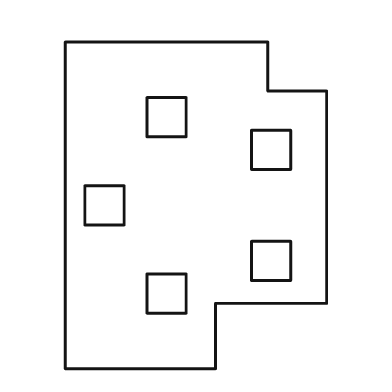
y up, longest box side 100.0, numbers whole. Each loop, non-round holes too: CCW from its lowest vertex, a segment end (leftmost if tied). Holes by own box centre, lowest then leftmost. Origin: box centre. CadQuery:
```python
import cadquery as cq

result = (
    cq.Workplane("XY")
    .moveTo(-40.0, -50.0)
    .lineTo(6.0, -50.0)
    .lineTo(6.0, -30.0)
    .lineTo(40.0, -30.0)
    .lineTo(40.0, 35.0)
    .lineTo(22.0, 35.0)
    .lineTo(22.0, 50.0)
    .lineTo(-40.0, 50.0)
    .close()
    .moveTo(-15.0, -33.0)
    .lineTo(-3.0, -33.0)
    .lineTo(-3.0, -21.0)
    .lineTo(-15.0, -21.0)
    .close()
    .moveTo(17.0, -23.0)
    .lineTo(29.0, -23.0)
    .lineTo(29.0, -11.0)
    .lineTo(17.0, -11.0)
    .close()
    .moveTo(-34.0, -6.0)
    .lineTo(-22.0, -6.0)
    .lineTo(-22.0, 6.0)
    .lineTo(-34.0, 6.0)
    .close()
    .moveTo(17.0, 11.0)
    .lineTo(29.0, 11.0)
    .lineTo(29.0, 23.0)
    .lineTo(17.0, 23.0)
    .close()
    .moveTo(-15.0, 21.0)
    .lineTo(-3.0, 21.0)
    .lineTo(-3.0, 33.0)
    .lineTo(-15.0, 33.0)
    .close()
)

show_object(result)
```